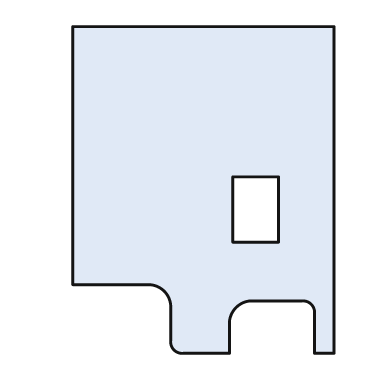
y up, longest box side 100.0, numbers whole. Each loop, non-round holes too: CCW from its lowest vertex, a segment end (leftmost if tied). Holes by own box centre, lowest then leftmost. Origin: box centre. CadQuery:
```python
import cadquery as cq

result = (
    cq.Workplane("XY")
    .moveTo(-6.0, -50.0)
    .lineTo(8.0, -50.0)
    .lineTo(8.0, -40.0)
    .threePointArc((10.0, -36.0), (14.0, -34.0))
    .lineTo(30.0, -34.0)
    .threePointArc((33.0, -35.0), (34.0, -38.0))
    .lineTo(34.0, -50.0)
    .lineTo(40.0, -50.0)
    .lineTo(40.0, 50.0)
    .lineTo(-40.0, 50.0)
    .lineTo(-40.0, -29.0)
    .lineTo(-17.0, -29.0)
    .threePointArc((-12.0, -31.0), (-10.0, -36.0))
    .lineTo(-10.0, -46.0)
    .threePointArc((-9.0, -49.0), (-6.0, -50.0))
    .close()
    .moveTo(9.0, -16.0)
    .lineTo(23.0, -16.0)
    .lineTo(23.0, 4.0)
    .lineTo(9.0, 4.0)
    .close()
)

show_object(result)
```